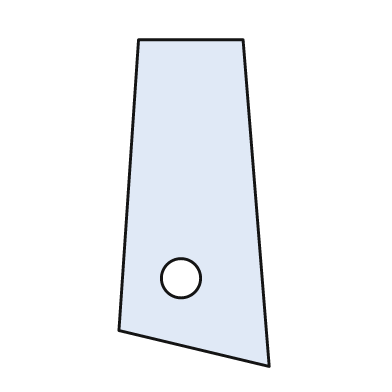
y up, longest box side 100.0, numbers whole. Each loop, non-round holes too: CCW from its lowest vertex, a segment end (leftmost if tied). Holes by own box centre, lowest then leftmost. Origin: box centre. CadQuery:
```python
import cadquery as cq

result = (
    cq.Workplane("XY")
    .moveTo(23.0, -50.0)
    .lineTo(15.0, 50.0)
    .lineTo(-17.0, 50.0)
    .lineTo(-23.0, -39.0)
    .close()
    .moveTo(-4.0, -23.0)
    .circle(6.0)
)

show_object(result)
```